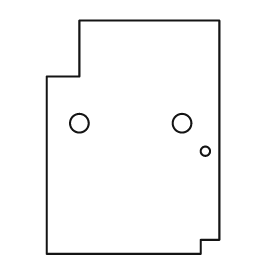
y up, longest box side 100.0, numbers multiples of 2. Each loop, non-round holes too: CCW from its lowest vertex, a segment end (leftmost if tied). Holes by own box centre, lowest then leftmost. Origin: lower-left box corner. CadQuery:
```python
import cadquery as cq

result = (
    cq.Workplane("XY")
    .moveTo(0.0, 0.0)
    .lineTo(66.0, 0.0)
    .lineTo(66.0, 6.0)
    .lineTo(74.0, 6.0)
    .lineTo(74.0, 100.0)
    .lineTo(14.0, 100.0)
    .lineTo(14.0, 76.0)
    .lineTo(0.0, 76.0)
    .close()
    .moveTo(68.0, 44.0)
    .circle(2.0)
    .moveTo(14.0, 56.0)
    .circle(4.0)
    .moveTo(58.0, 56.0)
    .circle(4.0)
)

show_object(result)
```